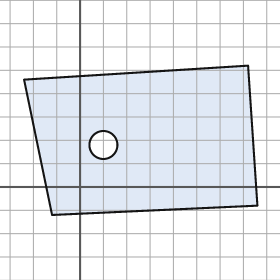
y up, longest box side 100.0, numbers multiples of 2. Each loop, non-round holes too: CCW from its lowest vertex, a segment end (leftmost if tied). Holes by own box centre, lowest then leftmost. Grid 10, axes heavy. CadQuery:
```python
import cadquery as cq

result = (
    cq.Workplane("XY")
    .moveTo(-12.0, -12.0)
    .lineTo(76.0, -8.0)
    .lineTo(72.0, 52.0)
    .lineTo(-24.0, 46.0)
    .close()
    .moveTo(10.0, 18.0)
    .circle(6.0)
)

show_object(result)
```